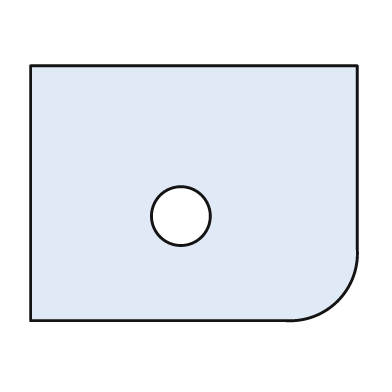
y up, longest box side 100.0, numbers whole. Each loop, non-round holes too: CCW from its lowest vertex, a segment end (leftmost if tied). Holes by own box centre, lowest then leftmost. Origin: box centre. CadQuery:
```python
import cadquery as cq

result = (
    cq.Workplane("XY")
    .moveTo(-50.0, -39.0)
    .lineTo(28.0, -39.0)
    .threePointArc((44.0, -33.0), (50.0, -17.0))
    .lineTo(50.0, 39.0)
    .lineTo(-50.0, 39.0)
    .close()
    .moveTo(-4.0, -7.0)
    .circle(9.0)
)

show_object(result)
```